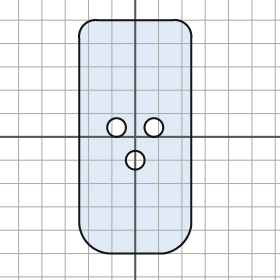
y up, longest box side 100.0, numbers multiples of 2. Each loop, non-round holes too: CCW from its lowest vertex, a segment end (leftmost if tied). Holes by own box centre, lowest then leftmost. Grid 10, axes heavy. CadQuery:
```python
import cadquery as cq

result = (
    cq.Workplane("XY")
    .moveTo(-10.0, -50.0)
    .lineTo(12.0, -50.0)
    .threePointArc((20.0, -46.0), (24.0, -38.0))
    .lineTo(24.0, 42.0)
    .threePointArc((22.0, 48.0), (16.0, 50.0))
    .lineTo(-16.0, 50.0)
    .threePointArc((-22.0, 48.0), (-24.0, 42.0))
    .lineTo(-24.0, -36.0)
    .threePointArc((-20.0, -46.0), (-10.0, -50.0))
    .close()
    .moveTo(0.0, -10.0)
    .circle(4.0)
    .moveTo(-8.0, 4.0)
    .circle(4.0)
    .moveTo(8.0, 4.0)
    .circle(4.0)
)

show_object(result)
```